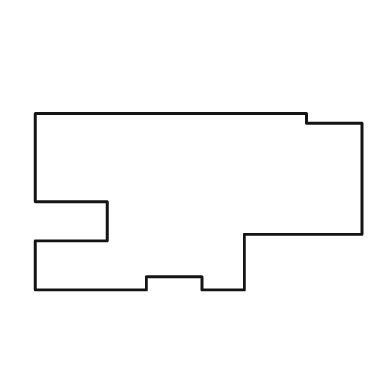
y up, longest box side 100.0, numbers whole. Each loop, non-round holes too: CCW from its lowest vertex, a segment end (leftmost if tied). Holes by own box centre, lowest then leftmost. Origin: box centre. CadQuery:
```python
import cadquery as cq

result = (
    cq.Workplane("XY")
    .moveTo(-50.0, -27.0)
    .lineTo(-16.0, -27.0)
    .lineTo(-16.0, -23.0)
    .lineTo(1.0, -23.0)
    .lineTo(1.0, -27.0)
    .lineTo(14.0, -27.0)
    .lineTo(14.0, -10.0)
    .lineTo(50.0, -10.0)
    .lineTo(50.0, 24.0)
    .lineTo(33.0, 24.0)
    .lineTo(33.0, 27.0)
    .lineTo(-50.0, 27.0)
    .lineTo(-50.0, 0.0)
    .lineTo(-28.0, 0.0)
    .lineTo(-28.0, -12.0)
    .lineTo(-50.0, -12.0)
    .close()
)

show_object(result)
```